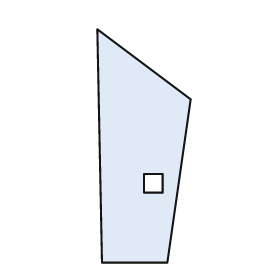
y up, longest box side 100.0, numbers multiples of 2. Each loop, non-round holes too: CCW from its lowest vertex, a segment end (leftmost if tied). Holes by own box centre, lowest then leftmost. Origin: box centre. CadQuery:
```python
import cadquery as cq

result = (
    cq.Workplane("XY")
    .moveTo(-18.0, -50.0)
    .lineTo(10.0, -50.0)
    .lineTo(20.0, 20.0)
    .lineTo(-20.0, 50.0)
    .close()
    .moveTo(0.0, -20.0)
    .lineTo(8.0, -20.0)
    .lineTo(8.0, -12.0)
    .lineTo(0.0, -12.0)
    .close()
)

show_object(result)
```